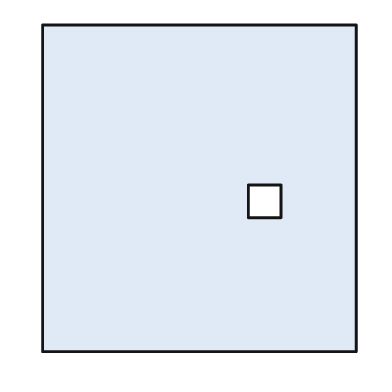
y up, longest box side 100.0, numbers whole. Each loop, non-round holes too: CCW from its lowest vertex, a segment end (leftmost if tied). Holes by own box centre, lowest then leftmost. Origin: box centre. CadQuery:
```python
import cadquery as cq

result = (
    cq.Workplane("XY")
    .moveTo(-48.0, -50.0)
    .lineTo(48.0, -50.0)
    .lineTo(48.0, 50.0)
    .lineTo(-48.0, 50.0)
    .close()
    .moveTo(15.0, -9.0)
    .lineTo(25.0, -9.0)
    .lineTo(25.0, 1.0)
    .lineTo(15.0, 1.0)
    .close()
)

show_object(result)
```